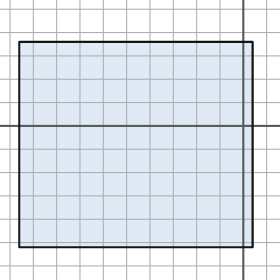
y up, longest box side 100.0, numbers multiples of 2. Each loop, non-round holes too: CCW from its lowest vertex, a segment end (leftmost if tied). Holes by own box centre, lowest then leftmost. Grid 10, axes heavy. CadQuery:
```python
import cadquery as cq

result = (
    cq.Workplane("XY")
    .moveTo(-96.0, -52.0)
    .lineTo(4.0, -52.0)
    .lineTo(4.0, 36.0)
    .lineTo(-96.0, 36.0)
    .close()
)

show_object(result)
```